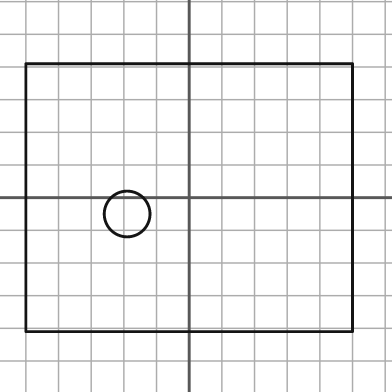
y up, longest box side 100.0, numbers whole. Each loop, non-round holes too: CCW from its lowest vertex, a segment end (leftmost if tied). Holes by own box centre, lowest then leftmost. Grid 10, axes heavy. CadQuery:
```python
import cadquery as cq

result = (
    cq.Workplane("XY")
    .moveTo(-50.0, -41.0)
    .lineTo(50.0, -41.0)
    .lineTo(50.0, 41.0)
    .lineTo(-50.0, 41.0)
    .close()
    .moveTo(-19.0, -5.0)
    .circle(7.0)
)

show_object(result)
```